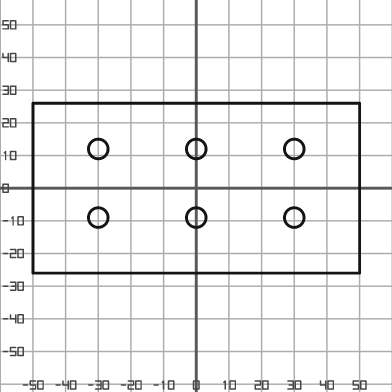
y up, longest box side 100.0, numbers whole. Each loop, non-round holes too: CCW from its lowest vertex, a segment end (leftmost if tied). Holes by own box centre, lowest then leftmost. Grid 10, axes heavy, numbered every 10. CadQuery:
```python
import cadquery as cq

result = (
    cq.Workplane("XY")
    .moveTo(-50.0, -26.0)
    .lineTo(50.0, -26.0)
    .lineTo(50.0, 26.0)
    .lineTo(-50.0, 26.0)
    .close()
    .moveTo(-30.0, -9.0)
    .circle(3.0)
    .moveTo(0.0, -9.0)
    .circle(3.0)
    .moveTo(30.0, -9.0)
    .circle(3.0)
    .moveTo(-30.0, 12.0)
    .circle(3.0)
    .moveTo(0.0, 12.0)
    .circle(3.0)
    .moveTo(30.0, 12.0)
    .circle(3.0)
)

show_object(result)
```